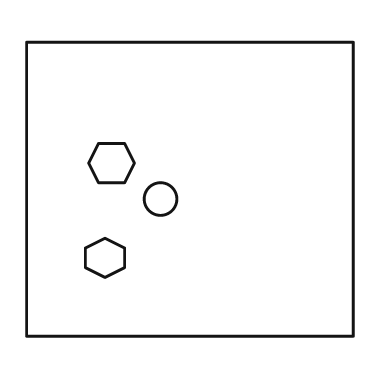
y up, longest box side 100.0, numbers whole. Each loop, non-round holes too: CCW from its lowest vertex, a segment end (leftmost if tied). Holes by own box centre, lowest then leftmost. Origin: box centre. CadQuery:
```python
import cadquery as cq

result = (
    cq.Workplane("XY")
    .moveTo(-50.0, -45.0)
    .lineTo(50.0, -45.0)
    .lineTo(50.0, 45.0)
    .lineTo(-50.0, 45.0)
    .close()
    .moveTo(-26.0, -27.0)
    .lineTo(-20.0, -24.0)
    .lineTo(-20.0, -18.0)
    .lineTo(-26.0, -15.0)
    .lineTo(-32.0, -18.0)
    .lineTo(-32.0, -24.0)
    .close()
    .moveTo(-9.0, -3.0)
    .circle(5.0)
    .moveTo(-28.0, 2.0)
    .lineTo(-20.0, 2.0)
    .lineTo(-17.0, 8.0)
    .lineTo(-20.0, 14.0)
    .lineTo(-28.0, 14.0)
    .lineTo(-31.0, 8.0)
    .close()
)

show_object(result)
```